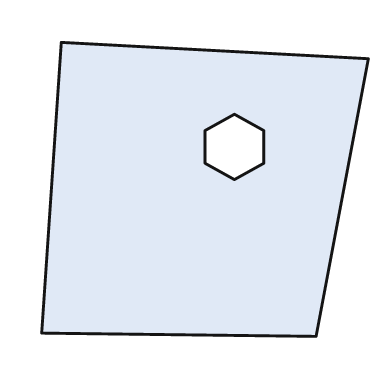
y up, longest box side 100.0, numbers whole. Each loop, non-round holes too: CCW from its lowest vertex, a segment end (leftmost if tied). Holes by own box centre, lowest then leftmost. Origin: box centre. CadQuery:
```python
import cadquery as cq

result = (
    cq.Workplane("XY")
    .moveTo(34.0, -45.0)
    .lineTo(50.0, 40.0)
    .lineTo(-44.0, 45.0)
    .lineTo(-50.0, -44.0)
    .close()
    .moveTo(9.0, 3.0)
    .lineTo(18.0, 8.0)
    .lineTo(18.0, 18.0)
    .lineTo(9.0, 23.0)
    .lineTo(0.0, 18.0)
    .lineTo(0.0, 8.0)
    .close()
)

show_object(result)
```